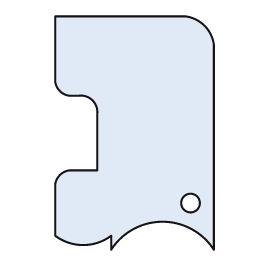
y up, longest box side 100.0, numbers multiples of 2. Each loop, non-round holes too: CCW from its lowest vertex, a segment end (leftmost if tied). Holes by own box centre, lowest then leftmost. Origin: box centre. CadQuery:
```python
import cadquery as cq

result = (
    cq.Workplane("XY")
    .moveTo(-10.0, -50.0)
    .threePointArc((12.0, -38.0), (34.0, -50.0))
    .lineTo(34.0, 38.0)
    .threePointArc((30.0, 46.0), (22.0, 50.0))
    .lineTo(-34.0, 50.0)
    .lineTo(-34.0, 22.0)
    .threePointArc((-32.0, 18.0), (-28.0, 16.0))
    .lineTo(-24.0, 16.0)
    .threePointArc((-18.0, 14.0), (-16.0, 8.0))
    .lineTo(-16.0, -16.0)
    .lineTo(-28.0, -16.0)
    .threePointArc((-32.0, -18.0), (-34.0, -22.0))
    .lineTo(-34.0, -44.0)
    .threePointArc((-22.0, -48.0), (-10.0, -44.0))
    .close()
    .moveTo(24.0, -30.0)
    .circle(4.0)
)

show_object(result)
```